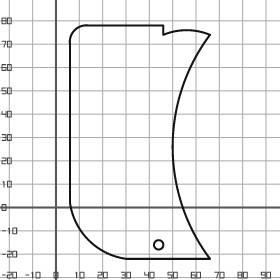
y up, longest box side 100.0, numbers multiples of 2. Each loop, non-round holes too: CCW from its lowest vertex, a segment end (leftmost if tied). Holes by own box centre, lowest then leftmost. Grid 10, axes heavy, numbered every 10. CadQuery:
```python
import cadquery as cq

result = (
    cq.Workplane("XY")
    .moveTo(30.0, -22.0)
    .lineTo(66.0, -22.0)
    .threePointArc((50.0, 26.0), (66.0, 74.0))
    .threePointArc((56.0, 76.0), (46.0, 74.0))
    .lineTo(46.0, 78.0)
    .lineTo(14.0, 78.0)
    .threePointArc((8.0, 76.0), (6.0, 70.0))
    .lineTo(6.0, 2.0)
    .threePointArc((14.0, -14.0), (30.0, -22.0))
    .close()
    .moveTo(44.0, -16.0)
    .circle(2.0)
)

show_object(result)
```